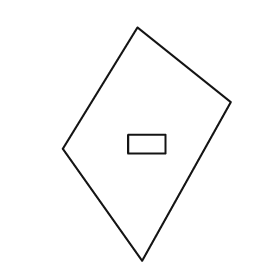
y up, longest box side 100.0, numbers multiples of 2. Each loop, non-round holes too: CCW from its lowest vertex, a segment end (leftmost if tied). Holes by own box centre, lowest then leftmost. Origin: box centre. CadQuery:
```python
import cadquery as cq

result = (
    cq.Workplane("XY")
    .moveTo(-2.0, -50.0)
    .lineTo(36.0, 18.0)
    .lineTo(-4.0, 50.0)
    .lineTo(-36.0, -2.0)
    .close()
    .moveTo(-8.0, -4.0)
    .lineTo(8.0, -4.0)
    .lineTo(8.0, 4.0)
    .lineTo(-8.0, 4.0)
    .close()
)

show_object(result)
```